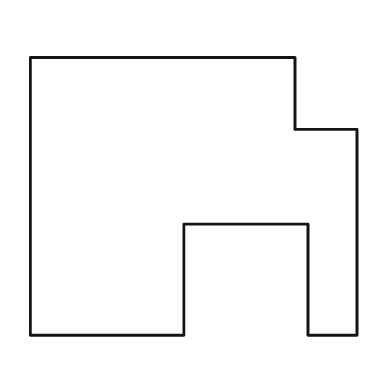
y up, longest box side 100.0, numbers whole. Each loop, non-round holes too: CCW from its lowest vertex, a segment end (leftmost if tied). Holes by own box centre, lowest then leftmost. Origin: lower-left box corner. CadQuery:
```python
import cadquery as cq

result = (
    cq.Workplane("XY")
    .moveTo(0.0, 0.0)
    .lineTo(47.0, 0.0)
    .lineTo(47.0, 34.0)
    .lineTo(85.0, 34.0)
    .lineTo(85.0, 0.0)
    .lineTo(100.0, 0.0)
    .lineTo(100.0, 63.0)
    .lineTo(81.0, 63.0)
    .lineTo(81.0, 85.0)
    .lineTo(0.0, 85.0)
    .close()
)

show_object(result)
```